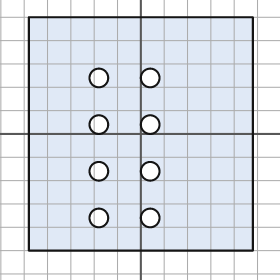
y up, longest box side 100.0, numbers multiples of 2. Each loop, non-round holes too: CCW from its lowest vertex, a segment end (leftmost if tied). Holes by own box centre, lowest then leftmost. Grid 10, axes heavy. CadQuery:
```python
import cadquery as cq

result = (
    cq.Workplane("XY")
    .moveTo(-48.0, -50.0)
    .lineTo(48.0, -50.0)
    .lineTo(48.0, 50.0)
    .lineTo(-48.0, 50.0)
    .close()
    .moveTo(-18.0, -36.0)
    .circle(4.0)
    .moveTo(4.0, -36.0)
    .circle(4.0)
    .moveTo(-18.0, -16.0)
    .circle(4.0)
    .moveTo(4.0, -16.0)
    .circle(4.0)
    .moveTo(-18.0, 4.0)
    .circle(4.0)
    .moveTo(4.0, 4.0)
    .circle(4.0)
    .moveTo(-18.0, 24.0)
    .circle(4.0)
    .moveTo(4.0, 24.0)
    .circle(4.0)
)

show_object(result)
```